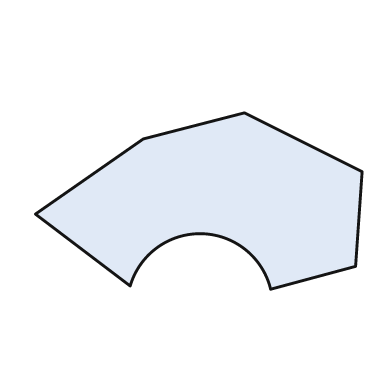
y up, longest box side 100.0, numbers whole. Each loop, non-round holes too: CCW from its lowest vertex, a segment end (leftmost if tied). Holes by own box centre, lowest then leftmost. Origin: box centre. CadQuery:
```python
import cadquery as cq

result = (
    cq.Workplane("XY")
    .moveTo(22.0, -27.0)
    .lineTo(48.0, -20.0)
    .lineTo(50.0, 9.0)
    .lineTo(14.0, 27.0)
    .lineTo(-17.0, 19.0)
    .lineTo(-50.0, -4.0)
    .lineTo(-21.0, -26.0)
    .threePointArc((1.0, -10.0), (22.0, -27.0))
    .close()
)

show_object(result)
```